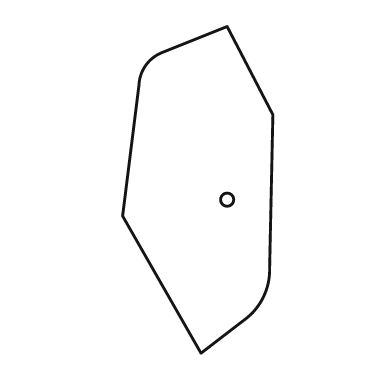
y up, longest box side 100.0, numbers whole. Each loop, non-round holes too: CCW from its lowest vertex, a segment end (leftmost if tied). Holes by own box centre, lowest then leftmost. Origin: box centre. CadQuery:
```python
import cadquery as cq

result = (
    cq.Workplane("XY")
    .moveTo(1.0, -50.0)
    .lineTo(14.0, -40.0)
    .threePointArc((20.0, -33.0), (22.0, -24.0))
    .lineTo(23.0, 23.0)
    .lineTo(9.0, 50.0)
    .lineTo(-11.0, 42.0)
    .threePointArc((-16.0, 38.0), (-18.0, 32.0))
    .lineTo(-23.0, -8.0)
    .close()
    .moveTo(9.0, -3.0)
    .circle(2.0)
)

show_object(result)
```